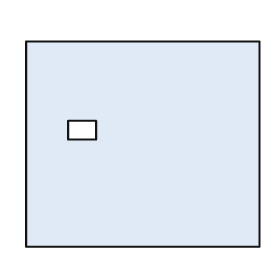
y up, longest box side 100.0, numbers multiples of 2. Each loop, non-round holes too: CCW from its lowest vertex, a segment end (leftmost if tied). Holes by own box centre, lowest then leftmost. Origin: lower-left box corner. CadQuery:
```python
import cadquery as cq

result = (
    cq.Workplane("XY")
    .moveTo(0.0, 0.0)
    .lineTo(100.0, 0.0)
    .lineTo(100.0, 88.0)
    .lineTo(0.0, 88.0)
    .close()
    .moveTo(18.0, 46.0)
    .lineTo(30.0, 46.0)
    .lineTo(30.0, 54.0)
    .lineTo(18.0, 54.0)
    .close()
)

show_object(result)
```